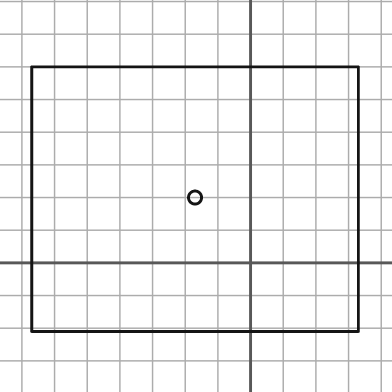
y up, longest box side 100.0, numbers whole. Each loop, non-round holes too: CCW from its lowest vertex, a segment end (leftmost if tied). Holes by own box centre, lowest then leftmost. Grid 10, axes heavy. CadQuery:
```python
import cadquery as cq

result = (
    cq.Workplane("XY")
    .moveTo(-67.0, -21.0)
    .lineTo(33.0, -21.0)
    .lineTo(33.0, 60.0)
    .lineTo(-67.0, 60.0)
    .close()
    .moveTo(-17.0, 20.0)
    .circle(2.0)
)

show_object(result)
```